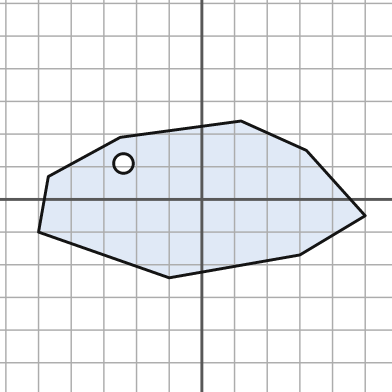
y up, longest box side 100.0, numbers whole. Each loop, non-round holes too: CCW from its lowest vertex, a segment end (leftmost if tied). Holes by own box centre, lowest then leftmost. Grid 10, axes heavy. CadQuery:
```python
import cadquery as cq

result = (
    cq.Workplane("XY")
    .moveTo(-10.0, -24.0)
    .lineTo(30.0, -17.0)
    .lineTo(50.0, -5.0)
    .lineTo(32.0, 15.0)
    .lineTo(12.0, 24.0)
    .lineTo(-25.0, 19.0)
    .lineTo(-47.0, 7.0)
    .lineTo(-50.0, -10.0)
    .close()
    .moveTo(-24.0, 11.0)
    .circle(3.0)
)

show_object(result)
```